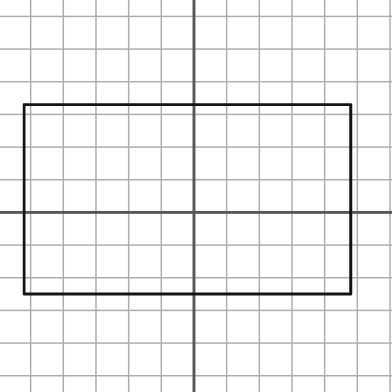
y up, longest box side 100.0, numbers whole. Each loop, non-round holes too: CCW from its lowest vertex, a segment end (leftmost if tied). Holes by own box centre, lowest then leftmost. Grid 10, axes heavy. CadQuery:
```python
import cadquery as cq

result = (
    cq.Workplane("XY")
    .moveTo(-52.0, -25.0)
    .lineTo(48.0, -25.0)
    .lineTo(48.0, 33.0)
    .lineTo(-52.0, 33.0)
    .close()
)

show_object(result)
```